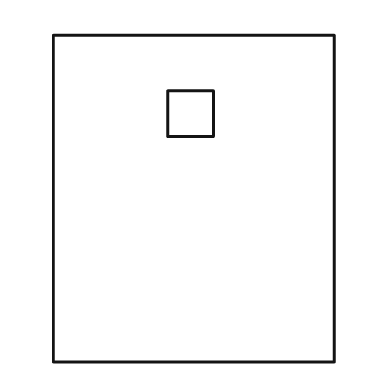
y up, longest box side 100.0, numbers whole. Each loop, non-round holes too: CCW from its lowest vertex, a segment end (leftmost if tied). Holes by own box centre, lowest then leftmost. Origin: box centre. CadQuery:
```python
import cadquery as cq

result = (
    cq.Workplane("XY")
    .moveTo(-43.0, -50.0)
    .lineTo(43.0, -50.0)
    .lineTo(43.0, 50.0)
    .lineTo(-43.0, 50.0)
    .close()
    .moveTo(-8.0, 19.0)
    .lineTo(6.0, 19.0)
    .lineTo(6.0, 33.0)
    .lineTo(-8.0, 33.0)
    .close()
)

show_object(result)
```